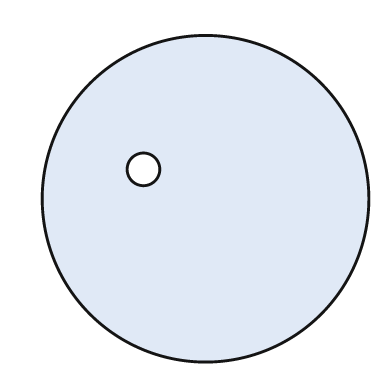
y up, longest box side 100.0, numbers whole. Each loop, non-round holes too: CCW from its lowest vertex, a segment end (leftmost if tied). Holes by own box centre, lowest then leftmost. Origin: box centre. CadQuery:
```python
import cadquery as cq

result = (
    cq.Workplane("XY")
    .moveTo(0.0, 0.0)
    .circle(50.0)
    .moveTo(-19.0, 9.0)
    .circle(5.0)
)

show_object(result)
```